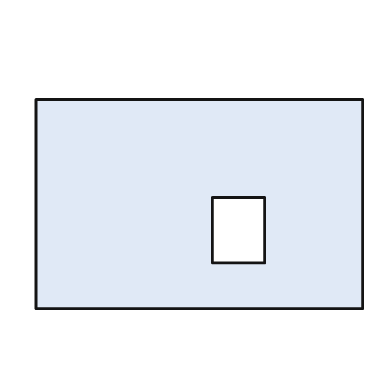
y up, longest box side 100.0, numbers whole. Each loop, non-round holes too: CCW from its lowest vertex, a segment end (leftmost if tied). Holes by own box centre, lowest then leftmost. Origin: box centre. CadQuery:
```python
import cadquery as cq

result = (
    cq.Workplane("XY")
    .moveTo(-50.0, -32.0)
    .lineTo(50.0, -32.0)
    .lineTo(50.0, 32.0)
    .lineTo(-50.0, 32.0)
    .close()
    .moveTo(4.0, -18.0)
    .lineTo(20.0, -18.0)
    .lineTo(20.0, 2.0)
    .lineTo(4.0, 2.0)
    .close()
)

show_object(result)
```